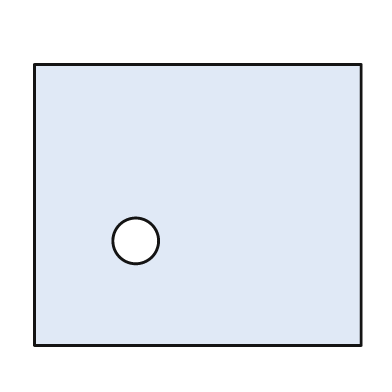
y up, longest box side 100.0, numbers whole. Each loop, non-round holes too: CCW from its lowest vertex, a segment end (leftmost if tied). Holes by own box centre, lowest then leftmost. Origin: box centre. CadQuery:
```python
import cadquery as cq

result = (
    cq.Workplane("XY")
    .moveTo(-50.0, -43.0)
    .lineTo(50.0, -43.0)
    .lineTo(50.0, 43.0)
    .lineTo(-50.0, 43.0)
    .close()
    .moveTo(-19.0, -11.0)
    .circle(7.0)
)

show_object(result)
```